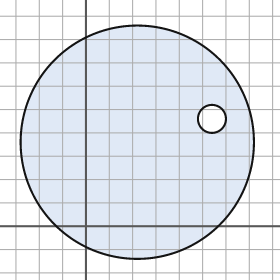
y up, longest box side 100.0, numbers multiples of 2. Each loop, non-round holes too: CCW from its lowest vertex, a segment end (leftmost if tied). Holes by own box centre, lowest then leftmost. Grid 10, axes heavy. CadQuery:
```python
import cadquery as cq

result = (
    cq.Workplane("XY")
    .moveTo(22.0, 36.0)
    .circle(50.0)
    .moveTo(54.0, 46.0)
    .circle(6.0)
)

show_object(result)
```